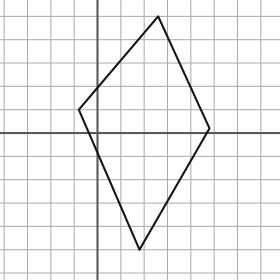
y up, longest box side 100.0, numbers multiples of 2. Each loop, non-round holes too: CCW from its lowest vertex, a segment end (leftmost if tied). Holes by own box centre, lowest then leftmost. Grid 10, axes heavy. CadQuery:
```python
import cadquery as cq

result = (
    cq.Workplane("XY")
    .moveTo(18.0, -50.0)
    .lineTo(48.0, 2.0)
    .lineTo(26.0, 50.0)
    .lineTo(-8.0, 10.0)
    .close()
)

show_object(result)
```